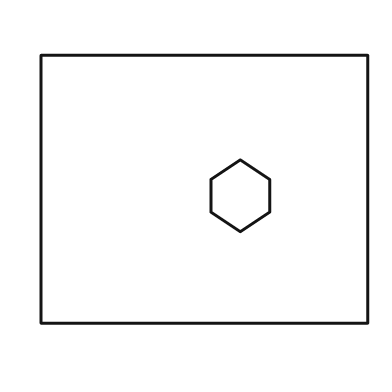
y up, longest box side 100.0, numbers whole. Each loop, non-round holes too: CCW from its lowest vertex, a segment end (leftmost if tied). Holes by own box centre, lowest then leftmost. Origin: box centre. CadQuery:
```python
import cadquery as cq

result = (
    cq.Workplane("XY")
    .moveTo(-50.0, -41.0)
    .lineTo(50.0, -41.0)
    .lineTo(50.0, 41.0)
    .lineTo(-50.0, 41.0)
    .close()
    .moveTo(11.0, -13.0)
    .lineTo(20.0, -7.0)
    .lineTo(20.0, 3.0)
    .lineTo(11.0, 9.0)
    .lineTo(2.0, 3.0)
    .lineTo(2.0, -7.0)
    .close()
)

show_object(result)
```